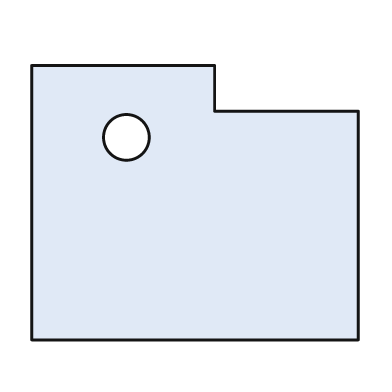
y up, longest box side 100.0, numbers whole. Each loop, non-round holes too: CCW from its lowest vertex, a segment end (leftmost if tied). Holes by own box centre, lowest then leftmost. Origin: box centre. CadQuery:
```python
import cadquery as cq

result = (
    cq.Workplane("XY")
    .moveTo(-50.0, -42.0)
    .lineTo(50.0, -42.0)
    .lineTo(50.0, 28.0)
    .lineTo(6.0, 28.0)
    .lineTo(6.0, 42.0)
    .lineTo(-50.0, 42.0)
    .close()
    .moveTo(-21.0, 20.0)
    .circle(7.0)
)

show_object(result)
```